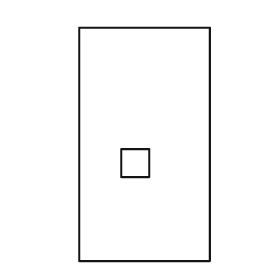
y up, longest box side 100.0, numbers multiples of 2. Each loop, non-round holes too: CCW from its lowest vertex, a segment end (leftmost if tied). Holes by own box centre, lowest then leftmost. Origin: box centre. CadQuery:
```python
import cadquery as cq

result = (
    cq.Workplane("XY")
    .moveTo(-28.0, -50.0)
    .lineTo(28.0, -50.0)
    .lineTo(28.0, 50.0)
    .lineTo(-28.0, 50.0)
    .close()
    .moveTo(-10.0, -14.0)
    .lineTo(2.0, -14.0)
    .lineTo(2.0, -2.0)
    .lineTo(-10.0, -2.0)
    .close()
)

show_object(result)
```